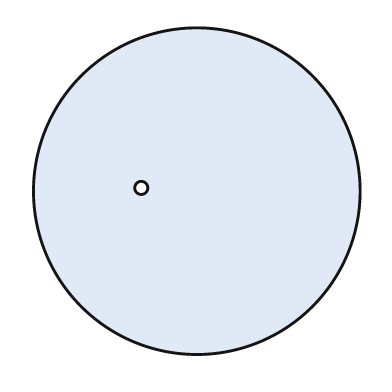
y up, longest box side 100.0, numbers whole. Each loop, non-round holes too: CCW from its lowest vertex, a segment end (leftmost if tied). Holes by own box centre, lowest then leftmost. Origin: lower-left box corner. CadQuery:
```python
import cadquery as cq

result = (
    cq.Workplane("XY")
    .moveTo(50.0, 50.0)
    .circle(50.0)
    .moveTo(33.0, 51.0)
    .circle(2.0)
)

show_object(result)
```